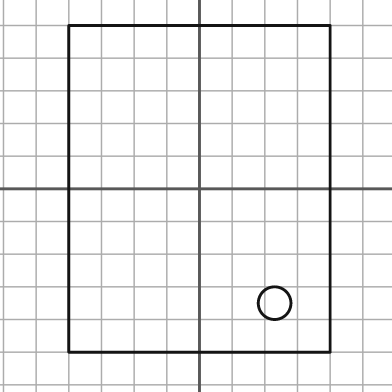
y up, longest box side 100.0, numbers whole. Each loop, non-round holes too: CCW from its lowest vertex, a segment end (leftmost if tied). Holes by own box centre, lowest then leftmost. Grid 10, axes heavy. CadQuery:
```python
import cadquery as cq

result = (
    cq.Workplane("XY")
    .moveTo(-40.0, -50.0)
    .lineTo(40.0, -50.0)
    .lineTo(40.0, 50.0)
    .lineTo(-40.0, 50.0)
    .close()
    .moveTo(23.0, -35.0)
    .circle(5.0)
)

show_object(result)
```